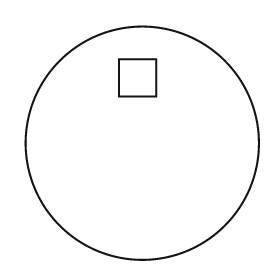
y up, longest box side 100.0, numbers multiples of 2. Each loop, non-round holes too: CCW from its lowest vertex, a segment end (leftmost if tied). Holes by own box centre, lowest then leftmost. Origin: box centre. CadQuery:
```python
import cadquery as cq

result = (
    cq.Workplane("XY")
    .moveTo(0.0, 0.0)
    .circle(50.0)
    .moveTo(-10.0, 20.0)
    .lineTo(6.0, 20.0)
    .lineTo(6.0, 36.0)
    .lineTo(-10.0, 36.0)
    .close()
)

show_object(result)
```